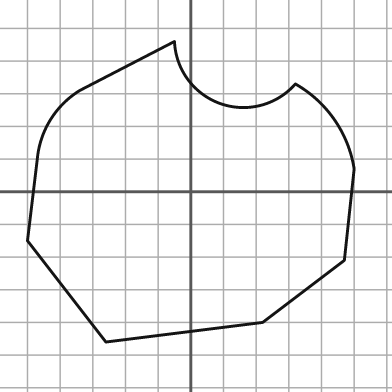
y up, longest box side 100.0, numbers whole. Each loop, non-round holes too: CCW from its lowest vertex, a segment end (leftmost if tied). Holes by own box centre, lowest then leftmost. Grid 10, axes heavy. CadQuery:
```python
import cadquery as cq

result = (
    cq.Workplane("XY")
    .moveTo(-26.0, -46.0)
    .lineTo(22.0, -40.0)
    .lineTo(47.0, -21.0)
    .lineTo(50.0, 7.0)
    .threePointArc((44.0, 22.0), (32.0, 33.0))
    .threePointArc((9.0, 27.0), (-5.0, 46.0))
    .lineTo(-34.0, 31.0)
    .threePointArc((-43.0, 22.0), (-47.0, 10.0))
    .lineTo(-50.0, -15.0)
    .close()
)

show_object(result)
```